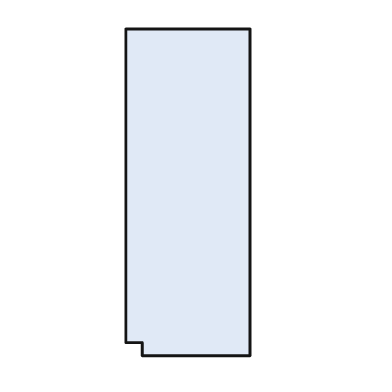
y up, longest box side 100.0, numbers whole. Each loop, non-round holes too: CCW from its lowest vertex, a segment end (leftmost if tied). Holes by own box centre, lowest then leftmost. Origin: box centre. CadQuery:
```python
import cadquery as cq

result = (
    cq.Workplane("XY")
    .moveTo(-14.0, -50.0)
    .lineTo(19.0, -50.0)
    .lineTo(19.0, 50.0)
    .lineTo(-19.0, 50.0)
    .lineTo(-19.0, -46.0)
    .lineTo(-14.0, -46.0)
    .close()
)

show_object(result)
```